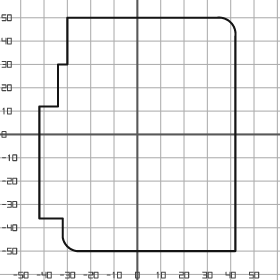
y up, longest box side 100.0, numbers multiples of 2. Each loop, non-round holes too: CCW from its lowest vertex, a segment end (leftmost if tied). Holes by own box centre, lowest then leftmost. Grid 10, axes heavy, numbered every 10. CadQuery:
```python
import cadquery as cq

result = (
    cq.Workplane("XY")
    .moveTo(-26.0, -50.0)
    .lineTo(42.0, -50.0)
    .lineTo(42.0, 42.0)
    .threePointArc((40.0, 48.0), (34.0, 50.0))
    .lineTo(-30.0, 50.0)
    .lineTo(-30.0, 30.0)
    .lineTo(-34.0, 30.0)
    .lineTo(-34.0, 12.0)
    .lineTo(-42.0, 12.0)
    .lineTo(-42.0, -36.0)
    .lineTo(-32.0, -36.0)
    .lineTo(-32.0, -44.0)
    .threePointArc((-30.0, -48.0), (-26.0, -50.0))
    .close()
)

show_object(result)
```